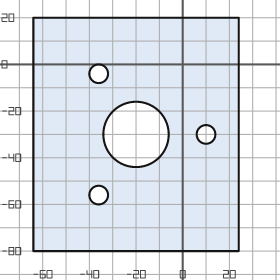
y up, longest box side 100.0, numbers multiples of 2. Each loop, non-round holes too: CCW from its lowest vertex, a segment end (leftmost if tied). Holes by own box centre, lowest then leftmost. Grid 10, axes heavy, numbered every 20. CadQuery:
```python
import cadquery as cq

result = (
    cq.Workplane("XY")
    .moveTo(-64.0, -80.0)
    .lineTo(24.0, -80.0)
    .lineTo(24.0, 20.0)
    .lineTo(-64.0, 20.0)
    .close()
    .moveTo(-36.0, -56.0)
    .circle(4.0)
    .moveTo(-20.0, -30.0)
    .circle(14.0)
    .moveTo(10.0, -30.0)
    .circle(4.0)
    .moveTo(-36.0, -4.0)
    .circle(4.0)
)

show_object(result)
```